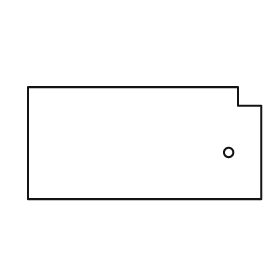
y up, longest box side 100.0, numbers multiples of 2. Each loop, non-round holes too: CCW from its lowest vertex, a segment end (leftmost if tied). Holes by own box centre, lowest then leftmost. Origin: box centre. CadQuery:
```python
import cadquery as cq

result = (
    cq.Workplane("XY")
    .moveTo(-50.0, -24.0)
    .lineTo(50.0, -24.0)
    .lineTo(50.0, 16.0)
    .lineTo(40.0, 16.0)
    .lineTo(40.0, 24.0)
    .lineTo(-50.0, 24.0)
    .close()
    .moveTo(36.0, -4.0)
    .circle(2.0)
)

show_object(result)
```